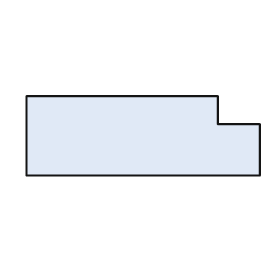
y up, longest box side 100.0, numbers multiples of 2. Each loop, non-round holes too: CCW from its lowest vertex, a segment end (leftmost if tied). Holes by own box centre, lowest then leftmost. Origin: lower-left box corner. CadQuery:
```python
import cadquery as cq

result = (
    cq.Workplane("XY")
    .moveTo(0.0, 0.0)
    .lineTo(100.0, 0.0)
    .lineTo(100.0, 22.0)
    .lineTo(82.0, 22.0)
    .lineTo(82.0, 34.0)
    .lineTo(0.0, 34.0)
    .close()
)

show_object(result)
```